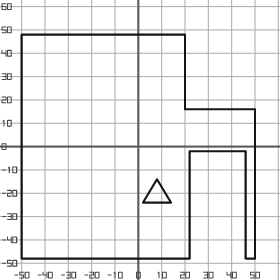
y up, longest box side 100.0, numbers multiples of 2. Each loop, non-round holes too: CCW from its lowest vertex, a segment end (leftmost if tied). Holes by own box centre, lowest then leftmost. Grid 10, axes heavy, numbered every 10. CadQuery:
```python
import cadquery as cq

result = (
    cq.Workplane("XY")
    .moveTo(-50.0, -48.0)
    .lineTo(22.0, -48.0)
    .lineTo(22.0, -2.0)
    .lineTo(46.0, -2.0)
    .lineTo(46.0, -48.0)
    .lineTo(50.0, -48.0)
    .lineTo(50.0, 16.0)
    .lineTo(20.0, 16.0)
    .lineTo(20.0, 48.0)
    .lineTo(-50.0, 48.0)
    .close()
    .moveTo(2.0, -24.0)
    .lineTo(14.0, -24.0)
    .lineTo(8.0, -14.0)
    .close()
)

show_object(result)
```